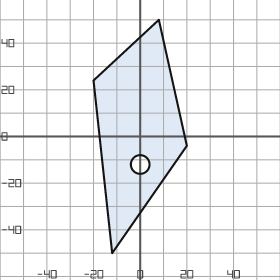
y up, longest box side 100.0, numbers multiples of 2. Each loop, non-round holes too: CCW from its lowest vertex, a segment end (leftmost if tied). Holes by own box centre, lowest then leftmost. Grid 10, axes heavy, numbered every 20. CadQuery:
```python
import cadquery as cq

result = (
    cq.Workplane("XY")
    .moveTo(-12.0, -50.0)
    .lineTo(20.0, -4.0)
    .lineTo(8.0, 50.0)
    .lineTo(-20.0, 24.0)
    .close()
    .moveTo(0.0, -12.0)
    .circle(4.0)
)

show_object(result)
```